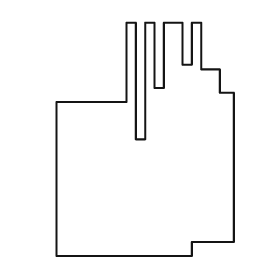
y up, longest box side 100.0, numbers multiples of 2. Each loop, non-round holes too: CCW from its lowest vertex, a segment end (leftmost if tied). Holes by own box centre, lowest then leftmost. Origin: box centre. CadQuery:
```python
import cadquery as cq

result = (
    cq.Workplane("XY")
    .moveTo(-38.0, -50.0)
    .lineTo(20.0, -50.0)
    .lineTo(20.0, -44.0)
    .lineTo(38.0, -44.0)
    .lineTo(38.0, 20.0)
    .lineTo(32.0, 20.0)
    .lineTo(32.0, 30.0)
    .lineTo(24.0, 30.0)
    .lineTo(24.0, 50.0)
    .lineTo(20.0, 50.0)
    .lineTo(20.0, 32.0)
    .lineTo(16.0, 32.0)
    .lineTo(16.0, 50.0)
    .lineTo(8.0, 50.0)
    .lineTo(8.0, 22.0)
    .lineTo(4.0, 22.0)
    .lineTo(4.0, 50.0)
    .lineTo(0.0, 50.0)
    .lineTo(0.0, 0.0)
    .lineTo(-4.0, 0.0)
    .lineTo(-4.0, 50.0)
    .lineTo(-8.0, 50.0)
    .lineTo(-8.0, 16.0)
    .lineTo(-38.0, 16.0)
    .close()
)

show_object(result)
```